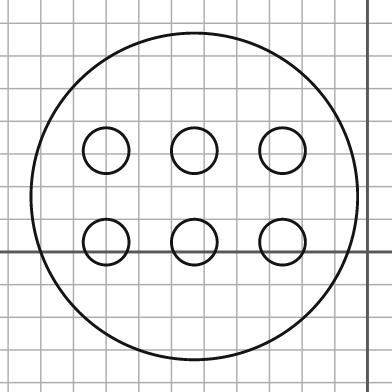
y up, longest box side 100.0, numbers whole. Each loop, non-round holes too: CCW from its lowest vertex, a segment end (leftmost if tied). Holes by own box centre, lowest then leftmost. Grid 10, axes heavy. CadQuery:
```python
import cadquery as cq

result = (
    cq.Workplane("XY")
    .moveTo(-53.0, 17.0)
    .circle(50.0)
    .moveTo(-80.0, 3.0)
    .circle(7.0)
    .moveTo(-53.0, 3.0)
    .circle(7.0)
    .moveTo(-26.0, 3.0)
    .circle(7.0)
    .moveTo(-80.0, 31.0)
    .circle(7.0)
    .moveTo(-53.0, 31.0)
    .circle(7.0)
    .moveTo(-26.0, 31.0)
    .circle(7.0)
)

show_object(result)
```